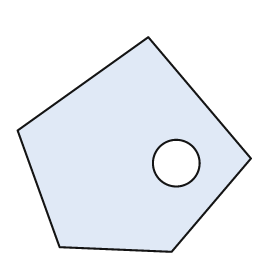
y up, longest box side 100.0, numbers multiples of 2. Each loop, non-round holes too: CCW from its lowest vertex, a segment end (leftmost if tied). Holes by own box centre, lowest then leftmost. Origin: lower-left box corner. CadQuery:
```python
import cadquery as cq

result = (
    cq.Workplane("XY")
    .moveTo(66.0, 0.0)
    .lineTo(100.0, 40.0)
    .lineTo(56.0, 92.0)
    .lineTo(0.0, 52.0)
    .lineTo(18.0, 2.0)
    .close()
    .moveTo(68.0, 38.0)
    .circle(10.0)
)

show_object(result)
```